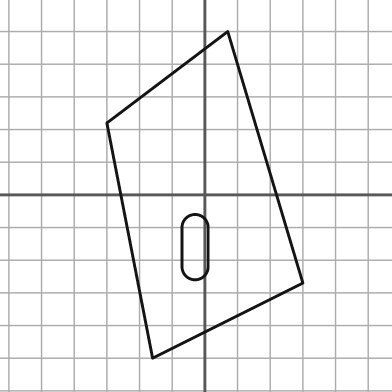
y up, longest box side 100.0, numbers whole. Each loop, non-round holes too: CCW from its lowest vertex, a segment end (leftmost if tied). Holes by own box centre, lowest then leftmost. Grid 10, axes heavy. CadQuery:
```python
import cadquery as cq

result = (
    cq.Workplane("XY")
    .moveTo(-16.0, -50.0)
    .lineTo(30.0, -27.0)
    .lineTo(7.0, 50.0)
    .lineTo(-30.0, 22.0)
    .close()
    .moveTo(-7.0, -22.0)
    .threePointArc((-3.0, -26.0), (1.0, -22.0))
    .lineTo(1.0, -10.0)
    .threePointArc((-3.0, -6.0), (-7.0, -10.0))
    .close()
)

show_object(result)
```